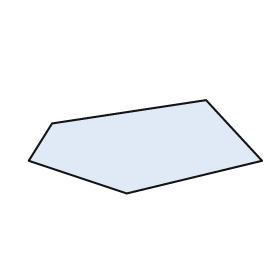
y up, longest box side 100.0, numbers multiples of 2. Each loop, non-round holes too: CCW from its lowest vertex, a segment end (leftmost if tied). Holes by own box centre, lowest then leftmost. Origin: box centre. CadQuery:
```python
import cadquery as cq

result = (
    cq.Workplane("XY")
    .moveTo(-8.0, -20.0)
    .lineTo(50.0, -6.0)
    .lineTo(26.0, 20.0)
    .lineTo(-40.0, 10.0)
    .lineTo(-50.0, -6.0)
    .close()
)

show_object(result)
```